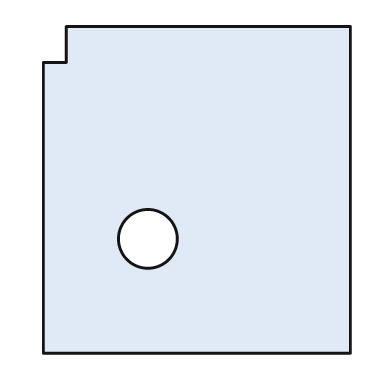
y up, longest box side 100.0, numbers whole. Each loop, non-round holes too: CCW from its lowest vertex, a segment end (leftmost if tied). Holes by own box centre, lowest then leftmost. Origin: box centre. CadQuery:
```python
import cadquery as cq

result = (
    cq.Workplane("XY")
    .moveTo(-47.0, -50.0)
    .lineTo(47.0, -50.0)
    .lineTo(47.0, 50.0)
    .lineTo(-40.0, 50.0)
    .lineTo(-40.0, 39.0)
    .lineTo(-47.0, 39.0)
    .close()
    .moveTo(-15.0, -15.0)
    .circle(9.0)
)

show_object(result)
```